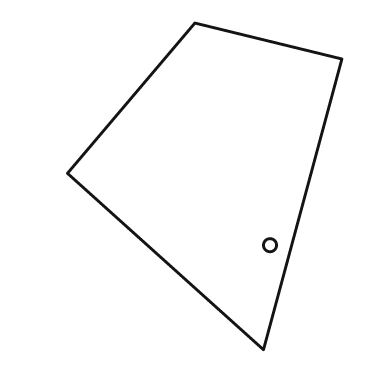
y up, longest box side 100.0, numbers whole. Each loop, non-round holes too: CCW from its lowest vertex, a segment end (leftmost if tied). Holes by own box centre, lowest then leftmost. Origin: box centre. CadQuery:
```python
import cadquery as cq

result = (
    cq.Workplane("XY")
    .moveTo(18.0, -50.0)
    .lineTo(42.0, 39.0)
    .lineTo(-3.0, 50.0)
    .lineTo(-42.0, 4.0)
    .close()
    .moveTo(20.0, -18.0)
    .circle(2.0)
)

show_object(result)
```